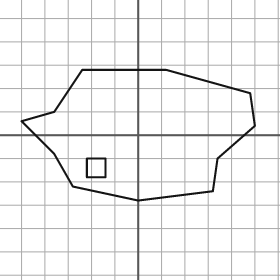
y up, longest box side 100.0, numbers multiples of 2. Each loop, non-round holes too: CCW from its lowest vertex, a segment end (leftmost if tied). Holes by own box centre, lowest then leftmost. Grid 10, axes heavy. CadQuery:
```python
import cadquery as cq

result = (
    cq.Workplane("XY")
    .moveTo(0.0, -28.0)
    .lineTo(32.0, -24.0)
    .lineTo(34.0, -10.0)
    .lineTo(50.0, 4.0)
    .lineTo(48.0, 18.0)
    .lineTo(12.0, 28.0)
    .lineTo(-24.0, 28.0)
    .lineTo(-36.0, 10.0)
    .lineTo(-50.0, 6.0)
    .lineTo(-36.0, -8.0)
    .lineTo(-28.0, -22.0)
    .close()
    .moveTo(-22.0, -18.0)
    .lineTo(-14.0, -18.0)
    .lineTo(-14.0, -10.0)
    .lineTo(-22.0, -10.0)
    .close()
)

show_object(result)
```